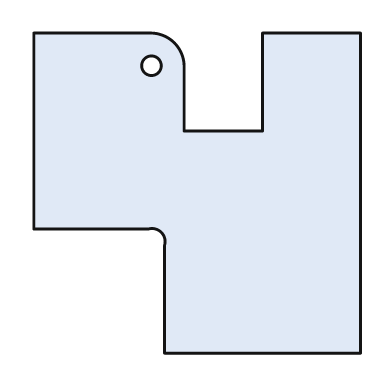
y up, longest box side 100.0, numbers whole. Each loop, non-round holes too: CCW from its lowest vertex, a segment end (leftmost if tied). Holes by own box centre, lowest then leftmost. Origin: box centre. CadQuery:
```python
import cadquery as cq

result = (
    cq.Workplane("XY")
    .moveTo(-10.0, -49.0)
    .lineTo(50.0, -49.0)
    .lineTo(50.0, 49.0)
    .lineTo(20.0, 49.0)
    .lineTo(20.0, 19.0)
    .lineTo(-4.0, 19.0)
    .lineTo(-4.0, 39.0)
    .threePointArc((-7.0, 46.0), (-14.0, 49.0))
    .lineTo(-50.0, 49.0)
    .lineTo(-50.0, -11.0)
    .lineTo(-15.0, -11.0)
    .threePointArc((-11.0, -12.0), (-10.0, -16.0))
    .close()
    .moveTo(-14.0, 39.0)
    .circle(3.0)
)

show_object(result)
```